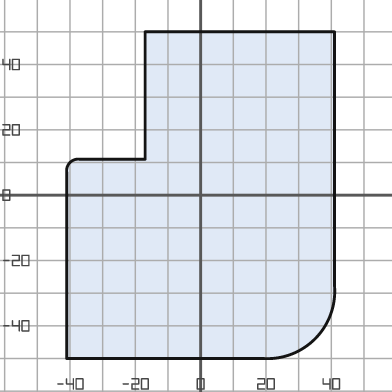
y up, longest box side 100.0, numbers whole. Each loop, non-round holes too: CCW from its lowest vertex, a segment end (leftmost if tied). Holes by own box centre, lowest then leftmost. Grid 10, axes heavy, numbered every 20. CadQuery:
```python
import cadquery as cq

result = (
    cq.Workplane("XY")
    .moveTo(-41.0, -50.0)
    .lineTo(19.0, -50.0)
    .threePointArc((35.0, -44.0), (41.0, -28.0))
    .lineTo(41.0, 50.0)
    .lineTo(-17.0, 50.0)
    .lineTo(-17.0, 11.0)
    .lineTo(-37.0, 11.0)
    .threePointArc((-40.0, 10.0), (-41.0, 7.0))
    .close()
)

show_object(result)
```